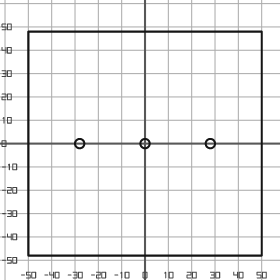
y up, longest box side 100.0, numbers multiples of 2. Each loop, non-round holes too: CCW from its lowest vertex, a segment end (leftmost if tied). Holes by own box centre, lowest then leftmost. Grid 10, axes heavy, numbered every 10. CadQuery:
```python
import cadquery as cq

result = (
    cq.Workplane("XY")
    .moveTo(-50.0, -48.0)
    .lineTo(50.0, -48.0)
    .lineTo(50.0, 48.0)
    .lineTo(-50.0, 48.0)
    .close()
    .moveTo(-28.0, 0.0)
    .circle(2.0)
    .moveTo(0.0, 0.0)
    .circle(2.0)
    .moveTo(28.0, 0.0)
    .circle(2.0)
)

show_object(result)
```